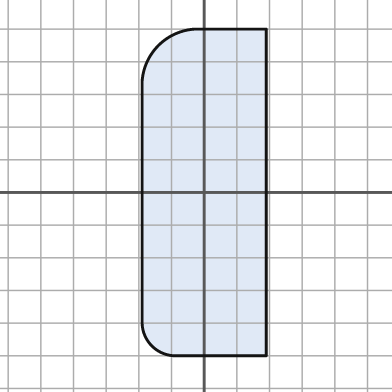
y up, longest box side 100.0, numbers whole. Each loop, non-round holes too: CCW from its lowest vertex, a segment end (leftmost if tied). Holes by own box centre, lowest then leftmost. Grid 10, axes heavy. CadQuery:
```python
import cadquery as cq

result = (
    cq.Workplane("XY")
    .moveTo(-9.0, -50.0)
    .lineTo(19.0, -50.0)
    .lineTo(19.0, 50.0)
    .lineTo(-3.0, 50.0)
    .threePointArc((-14.0, 45.0), (-19.0, 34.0))
    .lineTo(-19.0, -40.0)
    .threePointArc((-16.0, -47.0), (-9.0, -50.0))
    .close()
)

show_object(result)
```